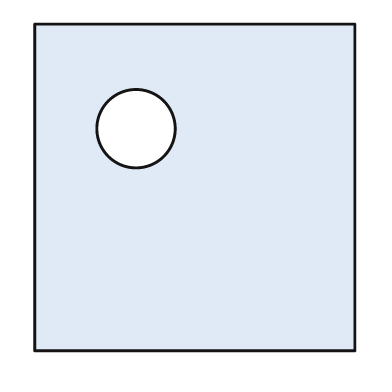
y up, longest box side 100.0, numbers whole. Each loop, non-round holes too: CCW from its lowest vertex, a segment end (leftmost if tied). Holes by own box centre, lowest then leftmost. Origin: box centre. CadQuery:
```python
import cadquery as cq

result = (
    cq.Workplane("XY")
    .moveTo(-49.0, -50.0)
    .lineTo(49.0, -50.0)
    .lineTo(49.0, 50.0)
    .lineTo(-49.0, 50.0)
    .close()
    .moveTo(-18.0, 18.0)
    .circle(12.0)
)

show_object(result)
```